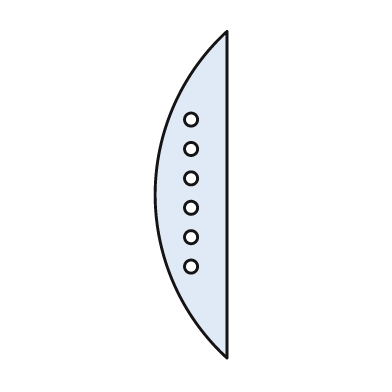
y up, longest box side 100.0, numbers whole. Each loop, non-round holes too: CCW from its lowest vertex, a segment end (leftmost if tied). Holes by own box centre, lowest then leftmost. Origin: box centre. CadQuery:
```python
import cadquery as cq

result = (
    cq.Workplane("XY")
    .moveTo(11.0, -50.0)
    .lineTo(11.0, 50.0)
    .threePointArc((-11.0, 0.0), (11.0, -50.0))
    .close()
    .moveTo(0.0, -22.0)
    .circle(2.0)
    .moveTo(0.0, -13.0)
    .circle(2.0)
    .moveTo(0.0, -4.0)
    .circle(2.0)
    .moveTo(0.0, 5.0)
    .circle(2.0)
    .moveTo(0.0, 14.0)
    .circle(2.0)
    .moveTo(0.0, 23.0)
    .circle(2.0)
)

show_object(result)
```